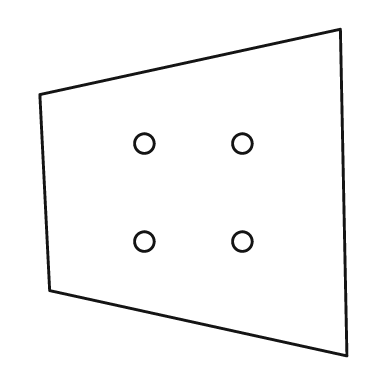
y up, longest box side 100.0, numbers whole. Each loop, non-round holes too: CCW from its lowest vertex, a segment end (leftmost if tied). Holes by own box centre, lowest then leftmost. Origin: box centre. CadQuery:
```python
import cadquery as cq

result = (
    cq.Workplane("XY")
    .moveTo(47.0, -50.0)
    .lineTo(45.0, 50.0)
    .lineTo(-47.0, 30.0)
    .lineTo(-44.0, -30.0)
    .close()
    .moveTo(-15.0, -15.0)
    .circle(3.0)
    .moveTo(15.0, -15.0)
    .circle(3.0)
    .moveTo(-15.0, 15.0)
    .circle(3.0)
    .moveTo(15.0, 15.0)
    .circle(3.0)
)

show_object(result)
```